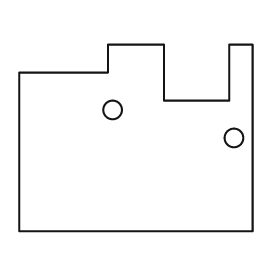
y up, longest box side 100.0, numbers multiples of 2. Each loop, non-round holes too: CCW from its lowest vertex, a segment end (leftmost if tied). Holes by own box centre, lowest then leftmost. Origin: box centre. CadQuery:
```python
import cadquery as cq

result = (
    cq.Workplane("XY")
    .moveTo(-50.0, -40.0)
    .lineTo(50.0, -40.0)
    .lineTo(50.0, 40.0)
    .lineTo(40.0, 40.0)
    .lineTo(40.0, 16.0)
    .lineTo(12.0, 16.0)
    .lineTo(12.0, 40.0)
    .lineTo(-12.0, 40.0)
    .lineTo(-12.0, 28.0)
    .lineTo(-50.0, 28.0)
    .close()
    .moveTo(42.0, 0.0)
    .circle(4.0)
    .moveTo(-10.0, 12.0)
    .circle(4.0)
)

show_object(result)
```